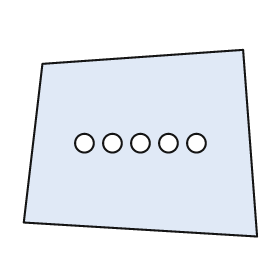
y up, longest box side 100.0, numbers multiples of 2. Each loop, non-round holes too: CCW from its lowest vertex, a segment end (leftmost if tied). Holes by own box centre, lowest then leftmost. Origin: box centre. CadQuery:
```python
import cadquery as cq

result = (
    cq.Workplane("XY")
    .moveTo(50.0, -40.0)
    .lineTo(44.0, 40.0)
    .lineTo(-42.0, 34.0)
    .lineTo(-50.0, -34.0)
    .close()
    .moveTo(-24.0, 0.0)
    .circle(4.0)
    .moveTo(-12.0, 0.0)
    .circle(4.0)
    .moveTo(0.0, 0.0)
    .circle(4.0)
    .moveTo(12.0, 0.0)
    .circle(4.0)
    .moveTo(24.0, 0.0)
    .circle(4.0)
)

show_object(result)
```